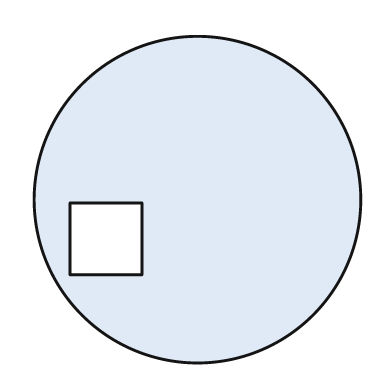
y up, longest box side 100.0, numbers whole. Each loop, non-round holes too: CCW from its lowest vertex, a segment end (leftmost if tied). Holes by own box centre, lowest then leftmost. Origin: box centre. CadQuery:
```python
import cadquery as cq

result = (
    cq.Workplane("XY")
    .moveTo(0.0, 0.0)
    .circle(50.0)
    .moveTo(-39.0, -23.0)
    .lineTo(-17.0, -23.0)
    .lineTo(-17.0, -1.0)
    .lineTo(-39.0, -1.0)
    .close()
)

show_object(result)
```